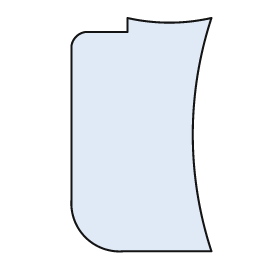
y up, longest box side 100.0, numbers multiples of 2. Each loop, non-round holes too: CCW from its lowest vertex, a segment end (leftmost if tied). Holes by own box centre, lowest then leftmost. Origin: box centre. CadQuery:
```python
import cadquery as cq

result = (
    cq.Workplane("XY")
    .moveTo(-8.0, -50.0)
    .lineTo(30.0, -50.0)
    .threePointArc((22.0, 0.0), (30.0, 50.0))
    .threePointArc((12.0, 48.0), (-6.0, 50.0))
    .lineTo(-6.0, 44.0)
    .lineTo(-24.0, 44.0)
    .threePointArc((-28.0, 42.0), (-30.0, 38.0))
    .lineTo(-30.0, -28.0)
    .threePointArc((-24.0, -44.0), (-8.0, -50.0))
    .close()
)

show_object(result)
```